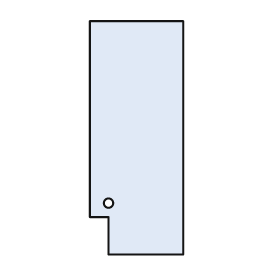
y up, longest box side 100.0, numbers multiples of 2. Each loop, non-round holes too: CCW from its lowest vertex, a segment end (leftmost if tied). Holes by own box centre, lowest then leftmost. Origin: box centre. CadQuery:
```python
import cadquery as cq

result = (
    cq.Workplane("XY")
    .moveTo(-12.0, -50.0)
    .lineTo(20.0, -50.0)
    .lineTo(20.0, 50.0)
    .lineTo(-20.0, 50.0)
    .lineTo(-20.0, -34.0)
    .lineTo(-12.0, -34.0)
    .close()
    .moveTo(-12.0, -28.0)
    .circle(2.0)
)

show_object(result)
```